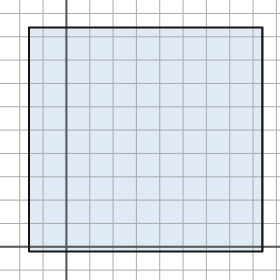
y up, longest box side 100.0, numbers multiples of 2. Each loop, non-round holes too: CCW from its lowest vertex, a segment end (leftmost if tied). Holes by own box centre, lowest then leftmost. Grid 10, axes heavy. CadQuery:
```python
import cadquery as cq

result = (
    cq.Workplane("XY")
    .moveTo(-16.0, -2.0)
    .lineTo(84.0, -2.0)
    .lineTo(84.0, 94.0)
    .lineTo(-16.0, 94.0)
    .close()
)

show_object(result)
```